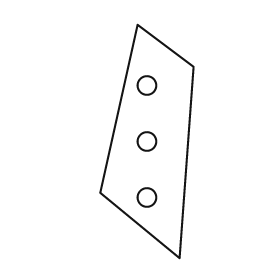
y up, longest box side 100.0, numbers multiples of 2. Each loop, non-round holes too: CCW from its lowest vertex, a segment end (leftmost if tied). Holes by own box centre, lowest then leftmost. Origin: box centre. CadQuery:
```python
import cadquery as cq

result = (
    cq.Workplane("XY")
    .moveTo(14.0, -50.0)
    .lineTo(20.0, 32.0)
    .lineTo(-4.0, 50.0)
    .lineTo(-20.0, -22.0)
    .close()
    .moveTo(0.0, -24.0)
    .circle(4.0)
    .moveTo(0.0, 0.0)
    .circle(4.0)
    .moveTo(0.0, 24.0)
    .circle(4.0)
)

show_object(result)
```